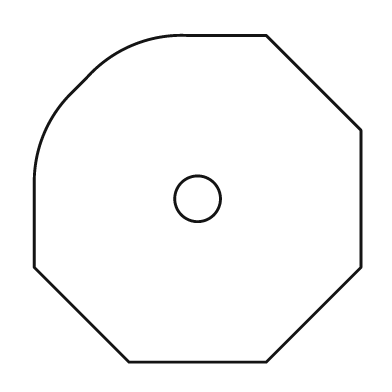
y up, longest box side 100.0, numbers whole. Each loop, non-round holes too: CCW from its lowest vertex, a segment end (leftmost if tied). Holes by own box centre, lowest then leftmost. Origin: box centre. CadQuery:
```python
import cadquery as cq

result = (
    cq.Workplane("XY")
    .moveTo(-21.0, -50.0)
    .lineTo(21.0, -50.0)
    .lineTo(50.0, -21.0)
    .lineTo(50.0, 21.0)
    .lineTo(21.0, 50.0)
    .lineTo(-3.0, 50.0)
    .threePointArc((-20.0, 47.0), (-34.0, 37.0))
    .lineTo(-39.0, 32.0)
    .threePointArc((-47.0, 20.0), (-50.0, 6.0))
    .lineTo(-50.0, -21.0)
    .close()
    .moveTo(0.0, 0.0)
    .circle(7.0)
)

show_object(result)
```